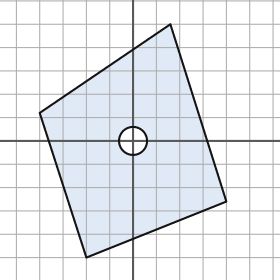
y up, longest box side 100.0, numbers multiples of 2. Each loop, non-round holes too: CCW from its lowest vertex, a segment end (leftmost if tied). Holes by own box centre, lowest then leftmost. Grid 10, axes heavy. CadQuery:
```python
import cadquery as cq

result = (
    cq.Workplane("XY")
    .moveTo(-20.0, -50.0)
    .lineTo(40.0, -26.0)
    .lineTo(16.0, 50.0)
    .lineTo(-40.0, 12.0)
    .close()
    .moveTo(0.0, 0.0)
    .circle(6.0)
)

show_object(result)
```